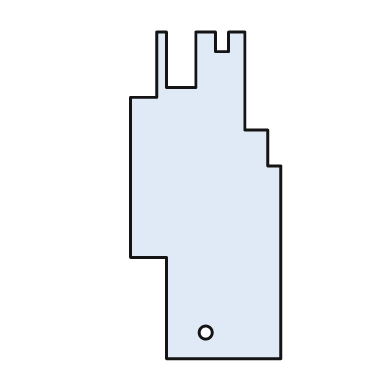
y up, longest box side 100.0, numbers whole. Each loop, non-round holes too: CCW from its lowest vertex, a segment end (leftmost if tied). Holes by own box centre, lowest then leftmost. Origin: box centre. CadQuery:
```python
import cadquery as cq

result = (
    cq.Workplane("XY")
    .moveTo(-12.0, -50.0)
    .lineTo(23.0, -50.0)
    .lineTo(23.0, 9.0)
    .lineTo(19.0, 9.0)
    .lineTo(19.0, 20.0)
    .lineTo(12.0, 20.0)
    .lineTo(12.0, 50.0)
    .lineTo(7.0, 50.0)
    .lineTo(7.0, 44.0)
    .lineTo(3.0, 44.0)
    .lineTo(3.0, 50.0)
    .lineTo(-3.0, 50.0)
    .lineTo(-3.0, 33.0)
    .lineTo(-12.0, 33.0)
    .lineTo(-12.0, 50.0)
    .lineTo(-15.0, 50.0)
    .lineTo(-15.0, 30.0)
    .lineTo(-23.0, 30.0)
    .lineTo(-23.0, -19.0)
    .lineTo(-12.0, -19.0)
    .close()
    .moveTo(0.0, -42.0)
    .circle(2.0)
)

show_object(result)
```